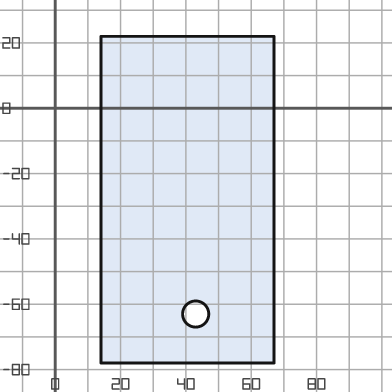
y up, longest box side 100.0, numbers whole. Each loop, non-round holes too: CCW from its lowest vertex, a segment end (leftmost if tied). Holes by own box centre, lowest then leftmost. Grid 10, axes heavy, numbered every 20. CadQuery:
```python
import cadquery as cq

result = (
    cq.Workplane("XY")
    .moveTo(14.0, -78.0)
    .lineTo(67.0, -78.0)
    .lineTo(67.0, 22.0)
    .lineTo(14.0, 22.0)
    .close()
    .moveTo(43.0, -63.0)
    .circle(4.0)
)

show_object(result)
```